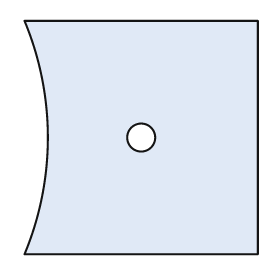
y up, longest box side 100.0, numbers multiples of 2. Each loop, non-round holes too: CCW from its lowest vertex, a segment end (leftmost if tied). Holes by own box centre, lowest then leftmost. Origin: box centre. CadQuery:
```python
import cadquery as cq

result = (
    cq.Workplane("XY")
    .moveTo(-50.0, -50.0)
    .lineTo(50.0, -50.0)
    .lineTo(50.0, 50.0)
    .lineTo(-50.0, 50.0)
    .threePointArc((-40.0, 0.0), (-50.0, -50.0))
    .close()
    .moveTo(0.0, 0.0)
    .circle(6.0)
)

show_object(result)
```